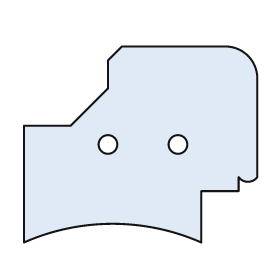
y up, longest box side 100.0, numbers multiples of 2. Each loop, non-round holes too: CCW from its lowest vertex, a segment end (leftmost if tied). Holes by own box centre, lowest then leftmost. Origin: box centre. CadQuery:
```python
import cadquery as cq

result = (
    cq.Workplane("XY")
    .moveTo(-50.0, -42.0)
    .threePointArc((-12.0, -34.0), (26.0, -42.0))
    .lineTo(26.0, -20.0)
    .lineTo(42.0, -20.0)
    .lineTo(42.0, -14.0)
    .threePointArc((46.0, -16.0), (50.0, -14.0))
    .lineTo(50.0, 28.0)
    .threePointArc((46.0, 38.0), (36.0, 42.0))
    .lineTo(-8.0, 42.0)
    .lineTo(-14.0, 36.0)
    .lineTo(-14.0, 24.0)
    .lineTo(-30.0, 8.0)
    .lineTo(-50.0, 8.0)
    .close()
    .moveTo(-14.0, 0.0)
    .circle(4.0)
    .moveTo(16.0, 0.0)
    .circle(4.0)
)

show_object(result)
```